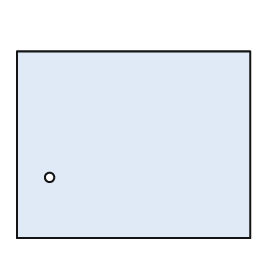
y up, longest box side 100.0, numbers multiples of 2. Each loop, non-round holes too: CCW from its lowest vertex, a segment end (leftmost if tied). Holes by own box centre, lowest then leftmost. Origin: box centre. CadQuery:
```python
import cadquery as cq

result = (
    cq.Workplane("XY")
    .moveTo(-50.0, -40.0)
    .lineTo(50.0, -40.0)
    .lineTo(50.0, 40.0)
    .lineTo(-50.0, 40.0)
    .close()
    .moveTo(-36.0, -14.0)
    .circle(2.0)
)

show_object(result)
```